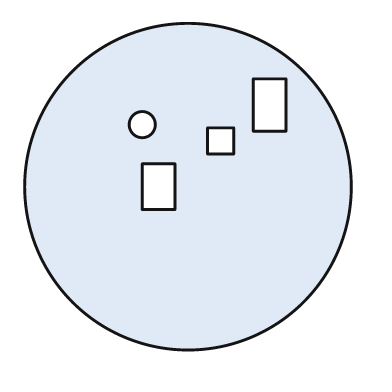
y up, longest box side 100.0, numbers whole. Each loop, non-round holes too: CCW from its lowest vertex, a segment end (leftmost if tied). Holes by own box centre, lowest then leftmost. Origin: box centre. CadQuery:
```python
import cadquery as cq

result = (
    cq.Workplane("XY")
    .moveTo(0.0, 0.0)
    .circle(50.0)
    .moveTo(-14.0, -7.0)
    .lineTo(-4.0, -7.0)
    .lineTo(-4.0, 7.0)
    .lineTo(-14.0, 7.0)
    .close()
    .moveTo(6.0, 10.0)
    .lineTo(14.0, 10.0)
    .lineTo(14.0, 18.0)
    .lineTo(6.0, 18.0)
    .close()
    .moveTo(-14.0, 19.0)
    .circle(4.0)
    .moveTo(20.0, 17.0)
    .lineTo(30.0, 17.0)
    .lineTo(30.0, 33.0)
    .lineTo(20.0, 33.0)
    .close()
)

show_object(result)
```